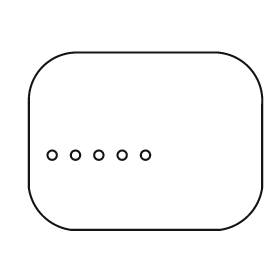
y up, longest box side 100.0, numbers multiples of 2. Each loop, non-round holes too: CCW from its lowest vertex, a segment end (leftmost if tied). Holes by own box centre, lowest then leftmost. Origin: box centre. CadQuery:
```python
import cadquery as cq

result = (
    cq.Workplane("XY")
    .moveTo(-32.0, -38.0)
    .lineTo(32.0, -38.0)
    .threePointArc((44.0, -32.0), (50.0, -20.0))
    .lineTo(50.0, 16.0)
    .threePointArc((44.0, 32.0), (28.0, 38.0))
    .lineTo(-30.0, 38.0)
    .threePointArc((-44.0, 32.0), (-50.0, 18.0))
    .lineTo(-50.0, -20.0)
    .threePointArc((-44.0, -32.0), (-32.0, -38.0))
    .close()
    .moveTo(-40.0, -6.0)
    .circle(2.0)
    .moveTo(-30.0, -6.0)
    .circle(2.0)
    .moveTo(-20.0, -6.0)
    .circle(2.0)
    .moveTo(-10.0, -6.0)
    .circle(2.0)
    .moveTo(0.0, -6.0)
    .circle(2.0)
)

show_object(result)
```